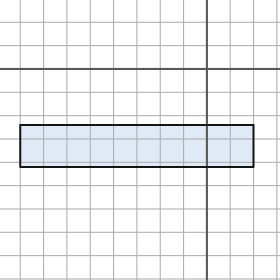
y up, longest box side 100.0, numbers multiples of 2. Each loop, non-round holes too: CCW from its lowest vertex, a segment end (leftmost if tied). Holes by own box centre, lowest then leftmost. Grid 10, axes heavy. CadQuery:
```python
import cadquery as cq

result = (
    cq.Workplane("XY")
    .moveTo(-80.0, -42.0)
    .lineTo(20.0, -42.0)
    .lineTo(20.0, -24.0)
    .lineTo(-80.0, -24.0)
    .close()
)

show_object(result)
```